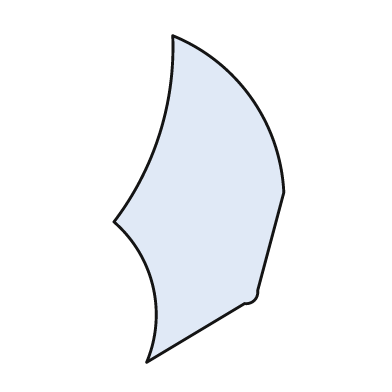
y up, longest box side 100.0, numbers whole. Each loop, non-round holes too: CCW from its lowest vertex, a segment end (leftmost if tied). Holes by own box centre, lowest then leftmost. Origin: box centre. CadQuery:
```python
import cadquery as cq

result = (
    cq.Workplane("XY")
    .moveTo(-16.0, -50.0)
    .lineTo(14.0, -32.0)
    .threePointArc((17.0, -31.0), (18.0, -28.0))
    .lineTo(26.0, 2.0)
    .threePointArc((16.0, 31.0), (-8.0, 50.0))
    .threePointArc((-12.0, 20.0), (-26.0, -7.0))
    .threePointArc((-14.0, -27.0), (-16.0, -50.0))
    .close()
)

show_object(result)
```